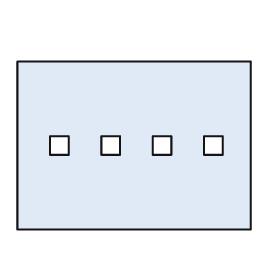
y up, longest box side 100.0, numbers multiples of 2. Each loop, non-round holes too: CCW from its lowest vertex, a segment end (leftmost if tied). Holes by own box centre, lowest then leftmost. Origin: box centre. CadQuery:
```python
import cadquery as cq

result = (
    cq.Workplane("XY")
    .moveTo(-50.0, -36.0)
    .lineTo(50.0, -36.0)
    .lineTo(50.0, 36.0)
    .lineTo(-50.0, 36.0)
    .close()
    .moveTo(-36.0, -4.0)
    .lineTo(-28.0, -4.0)
    .lineTo(-28.0, 4.0)
    .lineTo(-36.0, 4.0)
    .close()
    .moveTo(-14.0, -4.0)
    .lineTo(-6.0, -4.0)
    .lineTo(-6.0, 4.0)
    .lineTo(-14.0, 4.0)
    .close()
    .moveTo(8.0, -4.0)
    .lineTo(16.0, -4.0)
    .lineTo(16.0, 4.0)
    .lineTo(8.0, 4.0)
    .close()
    .moveTo(30.0, -4.0)
    .lineTo(38.0, -4.0)
    .lineTo(38.0, 4.0)
    .lineTo(30.0, 4.0)
    .close()
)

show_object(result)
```